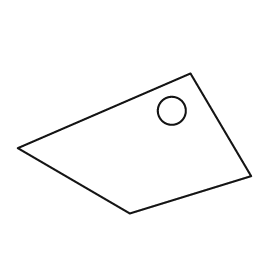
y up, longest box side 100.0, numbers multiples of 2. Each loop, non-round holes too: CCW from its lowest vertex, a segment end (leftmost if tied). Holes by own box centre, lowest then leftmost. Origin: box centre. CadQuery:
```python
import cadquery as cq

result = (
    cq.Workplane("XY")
    .moveTo(-2.0, -30.0)
    .lineTo(50.0, -14.0)
    .lineTo(24.0, 30.0)
    .lineTo(-50.0, -2.0)
    .close()
    .moveTo(16.0, 14.0)
    .circle(6.0)
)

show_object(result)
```